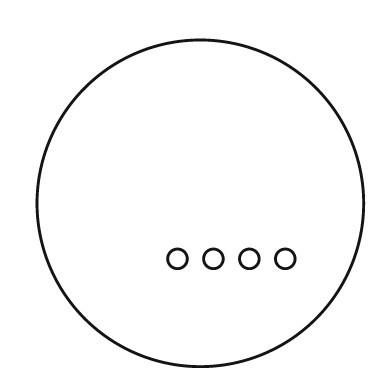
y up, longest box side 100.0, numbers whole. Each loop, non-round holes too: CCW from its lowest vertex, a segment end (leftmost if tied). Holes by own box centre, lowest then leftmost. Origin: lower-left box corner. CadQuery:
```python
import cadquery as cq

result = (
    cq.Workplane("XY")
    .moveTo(50.0, 50.0)
    .circle(50.0)
    .moveTo(43.0, 33.0)
    .circle(3.0)
    .moveTo(54.0, 33.0)
    .circle(3.0)
    .moveTo(65.0, 33.0)
    .circle(3.0)
    .moveTo(76.0, 33.0)
    .circle(3.0)
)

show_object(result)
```